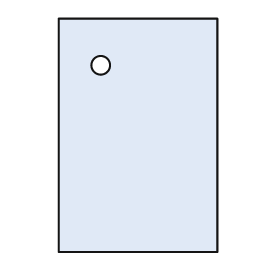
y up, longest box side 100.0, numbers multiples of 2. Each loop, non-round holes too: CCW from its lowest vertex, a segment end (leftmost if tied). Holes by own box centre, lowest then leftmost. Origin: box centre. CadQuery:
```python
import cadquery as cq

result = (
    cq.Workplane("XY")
    .moveTo(-34.0, -50.0)
    .lineTo(34.0, -50.0)
    .lineTo(34.0, 50.0)
    .lineTo(-34.0, 50.0)
    .close()
    .moveTo(-16.0, 30.0)
    .circle(4.0)
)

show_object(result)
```